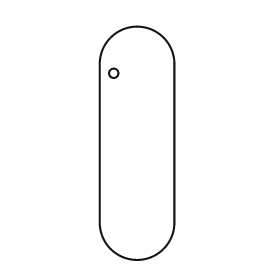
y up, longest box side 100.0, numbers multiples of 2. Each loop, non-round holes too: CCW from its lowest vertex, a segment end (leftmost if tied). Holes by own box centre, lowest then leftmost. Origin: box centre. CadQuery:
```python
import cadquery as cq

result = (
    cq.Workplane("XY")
    .moveTo(-16.0, -34.0)
    .threePointArc((0.0, -50.0), (16.0, -34.0))
    .lineTo(16.0, 34.0)
    .threePointArc((0.0, 50.0), (-16.0, 34.0))
    .close()
    .moveTo(-10.0, 30.0)
    .circle(2.0)
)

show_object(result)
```